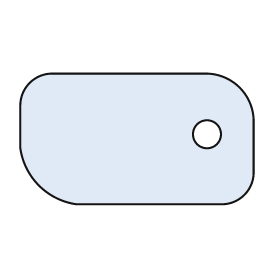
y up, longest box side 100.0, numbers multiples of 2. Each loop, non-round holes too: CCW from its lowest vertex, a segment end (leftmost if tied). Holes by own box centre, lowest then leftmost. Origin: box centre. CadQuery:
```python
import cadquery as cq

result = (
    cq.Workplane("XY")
    .moveTo(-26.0, -28.0)
    .lineTo(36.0, -28.0)
    .threePointArc((46.0, -24.0), (50.0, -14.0))
    .lineTo(50.0, 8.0)
    .threePointArc((44.0, 22.0), (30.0, 28.0))
    .lineTo(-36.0, 28.0)
    .threePointArc((-46.0, 24.0), (-50.0, 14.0))
    .lineTo(-50.0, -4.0)
    .threePointArc((-42.0, -20.0), (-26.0, -28.0))
    .close()
    .moveTo(30.0, 2.0)
    .circle(6.0)
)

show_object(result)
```